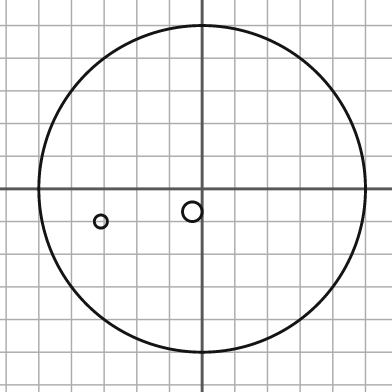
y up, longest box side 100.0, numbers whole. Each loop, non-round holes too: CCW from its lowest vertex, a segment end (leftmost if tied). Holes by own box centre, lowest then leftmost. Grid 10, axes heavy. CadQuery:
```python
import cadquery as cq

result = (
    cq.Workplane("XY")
    .moveTo(0.0, 0.0)
    .circle(50.0)
    .moveTo(-31.0, -10.0)
    .circle(2.0)
    .moveTo(-3.0, -7.0)
    .circle(3.0)
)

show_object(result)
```